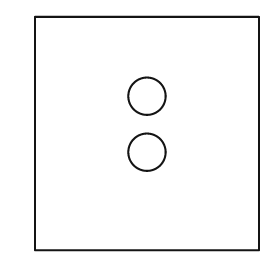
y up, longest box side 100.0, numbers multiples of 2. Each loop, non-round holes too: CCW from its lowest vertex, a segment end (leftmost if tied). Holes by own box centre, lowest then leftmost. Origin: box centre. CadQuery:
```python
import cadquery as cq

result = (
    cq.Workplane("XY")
    .moveTo(-48.0, -50.0)
    .lineTo(48.0, -50.0)
    .lineTo(48.0, 50.0)
    .lineTo(-48.0, 50.0)
    .close()
    .moveTo(0.0, -8.0)
    .circle(8.0)
    .moveTo(0.0, 16.0)
    .circle(8.0)
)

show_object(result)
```